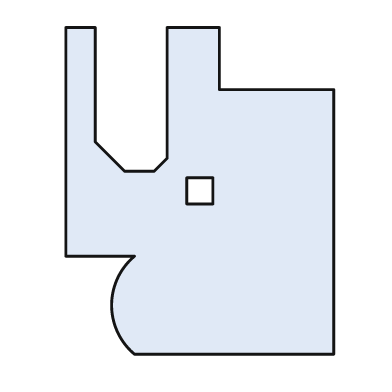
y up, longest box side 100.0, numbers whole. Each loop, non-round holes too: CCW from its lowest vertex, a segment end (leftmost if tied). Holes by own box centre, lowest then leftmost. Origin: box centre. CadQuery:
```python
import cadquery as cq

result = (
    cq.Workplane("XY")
    .moveTo(-20.0, -50.0)
    .lineTo(41.0, -50.0)
    .lineTo(41.0, 31.0)
    .lineTo(6.0, 31.0)
    .lineTo(6.0, 50.0)
    .lineTo(-10.0, 50.0)
    .lineTo(-10.0, 10.0)
    .lineTo(-14.0, 6.0)
    .lineTo(-23.0, 6.0)
    .lineTo(-32.0, 15.0)
    .lineTo(-32.0, 50.0)
    .lineTo(-41.0, 50.0)
    .lineTo(-41.0, -20.0)
    .lineTo(-20.0, -20.0)
    .threePointArc((-27.0, -35.0), (-20.0, -50.0))
    .close()
    .moveTo(-4.0, -4.0)
    .lineTo(4.0, -4.0)
    .lineTo(4.0, 4.0)
    .lineTo(-4.0, 4.0)
    .close()
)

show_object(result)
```